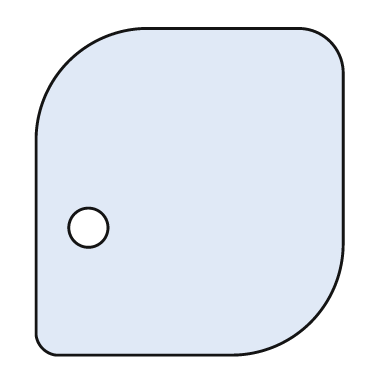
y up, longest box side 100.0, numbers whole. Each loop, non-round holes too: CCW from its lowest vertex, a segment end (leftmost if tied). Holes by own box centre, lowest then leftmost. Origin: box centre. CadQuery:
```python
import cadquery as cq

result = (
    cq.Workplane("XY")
    .moveTo(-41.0, -50.0)
    .lineTo(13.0, -50.0)
    .threePointArc((37.0, -40.0), (47.0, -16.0))
    .lineTo(47.0, 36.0)
    .threePointArc((43.0, 46.0), (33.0, 50.0))
    .lineTo(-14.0, 50.0)
    .threePointArc((-37.0, 40.0), (-47.0, 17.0))
    .lineTo(-47.0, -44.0)
    .threePointArc((-45.0, -48.0), (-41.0, -50.0))
    .close()
    .moveTo(-31.0, -11.0)
    .circle(6.0)
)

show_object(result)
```